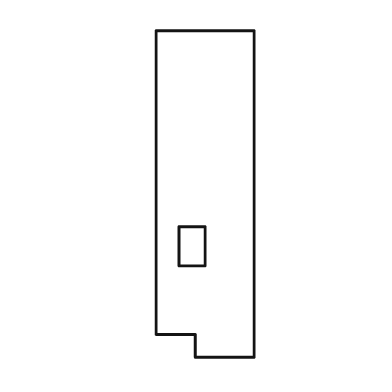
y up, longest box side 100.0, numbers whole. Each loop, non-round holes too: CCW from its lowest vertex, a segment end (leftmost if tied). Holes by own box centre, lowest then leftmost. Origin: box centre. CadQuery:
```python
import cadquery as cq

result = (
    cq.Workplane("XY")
    .moveTo(-3.0, -50.0)
    .lineTo(15.0, -50.0)
    .lineTo(15.0, 50.0)
    .lineTo(-15.0, 50.0)
    .lineTo(-15.0, -43.0)
    .lineTo(-3.0, -43.0)
    .close()
    .moveTo(-8.0, -22.0)
    .lineTo(0.0, -22.0)
    .lineTo(0.0, -10.0)
    .lineTo(-8.0, -10.0)
    .close()
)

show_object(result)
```